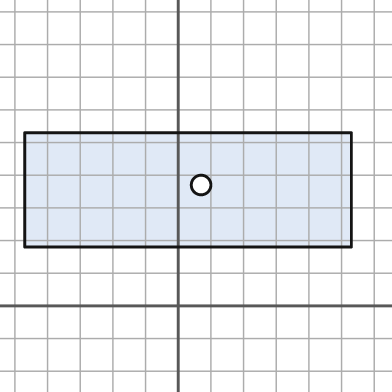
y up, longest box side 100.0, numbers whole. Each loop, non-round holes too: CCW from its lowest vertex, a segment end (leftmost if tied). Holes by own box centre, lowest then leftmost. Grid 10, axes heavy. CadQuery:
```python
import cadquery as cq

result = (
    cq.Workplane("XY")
    .moveTo(-47.0, 18.0)
    .lineTo(53.0, 18.0)
    .lineTo(53.0, 53.0)
    .lineTo(-47.0, 53.0)
    .close()
    .moveTo(7.0, 37.0)
    .circle(3.0)
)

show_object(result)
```